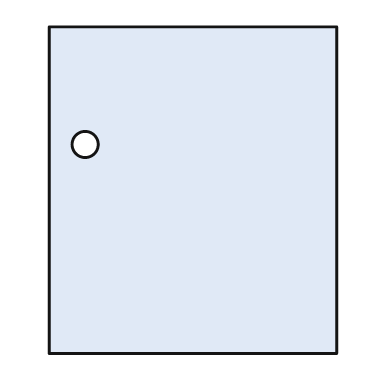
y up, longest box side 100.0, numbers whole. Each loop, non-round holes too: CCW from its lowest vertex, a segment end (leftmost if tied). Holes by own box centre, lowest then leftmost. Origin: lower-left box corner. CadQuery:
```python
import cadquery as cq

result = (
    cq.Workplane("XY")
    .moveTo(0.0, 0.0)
    .lineTo(88.0, 0.0)
    .lineTo(88.0, 100.0)
    .lineTo(0.0, 100.0)
    .close()
    .moveTo(11.0, 64.0)
    .circle(4.0)
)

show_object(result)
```